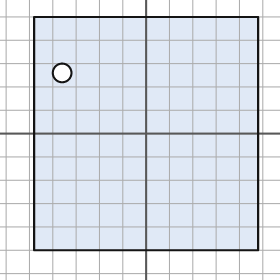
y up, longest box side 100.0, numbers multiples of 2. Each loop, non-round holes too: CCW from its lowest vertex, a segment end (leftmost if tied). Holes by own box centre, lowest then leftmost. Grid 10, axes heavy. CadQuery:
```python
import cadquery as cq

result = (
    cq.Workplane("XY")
    .moveTo(-48.0, -50.0)
    .lineTo(48.0, -50.0)
    .lineTo(48.0, 50.0)
    .lineTo(-48.0, 50.0)
    .close()
    .moveTo(-36.0, 26.0)
    .circle(4.0)
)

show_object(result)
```